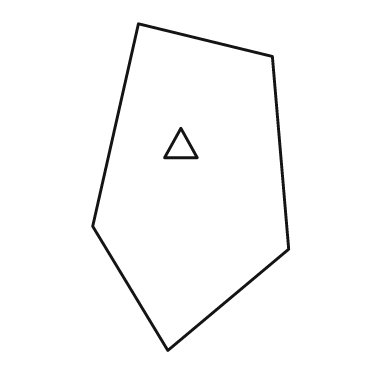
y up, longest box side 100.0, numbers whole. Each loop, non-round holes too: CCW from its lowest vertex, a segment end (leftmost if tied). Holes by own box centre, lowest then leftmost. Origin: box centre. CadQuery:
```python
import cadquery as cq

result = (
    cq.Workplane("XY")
    .moveTo(-7.0, -50.0)
    .lineTo(30.0, -19.0)
    .lineTo(25.0, 40.0)
    .lineTo(-16.0, 50.0)
    .lineTo(-30.0, -12.0)
    .close()
    .moveTo(-8.0, 9.0)
    .lineTo(2.0, 9.0)
    .lineTo(-3.0, 18.0)
    .close()
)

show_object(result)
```